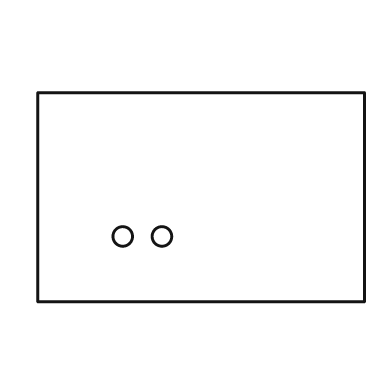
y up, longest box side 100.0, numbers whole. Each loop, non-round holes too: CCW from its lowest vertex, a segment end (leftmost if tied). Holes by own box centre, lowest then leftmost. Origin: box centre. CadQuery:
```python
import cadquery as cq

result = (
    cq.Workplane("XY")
    .moveTo(-50.0, -32.0)
    .lineTo(50.0, -32.0)
    .lineTo(50.0, 32.0)
    .lineTo(-50.0, 32.0)
    .close()
    .moveTo(-24.0, -12.0)
    .circle(3.0)
    .moveTo(-12.0, -12.0)
    .circle(3.0)
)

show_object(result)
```